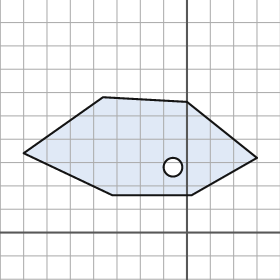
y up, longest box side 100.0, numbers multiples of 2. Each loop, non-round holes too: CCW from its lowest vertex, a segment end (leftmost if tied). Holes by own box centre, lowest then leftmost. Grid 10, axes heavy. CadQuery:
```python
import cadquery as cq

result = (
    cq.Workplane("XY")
    .moveTo(-32.0, 16.0)
    .lineTo(2.0, 16.0)
    .lineTo(30.0, 32.0)
    .lineTo(0.0, 56.0)
    .lineTo(-36.0, 58.0)
    .lineTo(-70.0, 34.0)
    .close()
    .moveTo(-6.0, 28.0)
    .circle(4.0)
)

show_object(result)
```